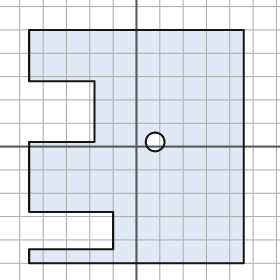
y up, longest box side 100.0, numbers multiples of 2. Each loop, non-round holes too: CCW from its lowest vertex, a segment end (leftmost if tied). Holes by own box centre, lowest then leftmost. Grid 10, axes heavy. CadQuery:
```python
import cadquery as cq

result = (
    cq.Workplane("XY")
    .moveTo(-46.0, -50.0)
    .lineTo(46.0, -50.0)
    .lineTo(46.0, 50.0)
    .lineTo(-46.0, 50.0)
    .lineTo(-46.0, 28.0)
    .lineTo(-18.0, 28.0)
    .lineTo(-18.0, 2.0)
    .lineTo(-46.0, 2.0)
    .lineTo(-46.0, -28.0)
    .lineTo(-10.0, -28.0)
    .lineTo(-10.0, -44.0)
    .lineTo(-46.0, -44.0)
    .close()
    .moveTo(8.0, 2.0)
    .circle(4.0)
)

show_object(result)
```